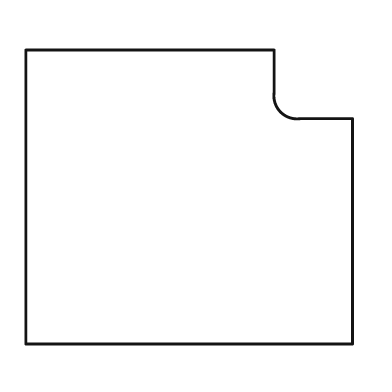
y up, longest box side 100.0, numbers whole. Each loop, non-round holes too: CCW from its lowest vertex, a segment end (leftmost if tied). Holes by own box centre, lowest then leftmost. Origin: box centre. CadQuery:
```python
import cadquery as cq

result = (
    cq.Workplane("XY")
    .moveTo(-50.0, -45.0)
    .lineTo(50.0, -45.0)
    .lineTo(50.0, 24.0)
    .lineTo(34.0, 24.0)
    .threePointArc((28.0, 26.0), (26.0, 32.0))
    .lineTo(26.0, 45.0)
    .lineTo(-50.0, 45.0)
    .close()
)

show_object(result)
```